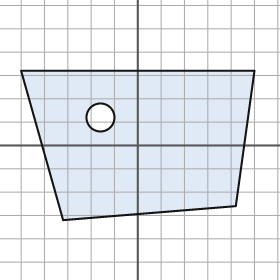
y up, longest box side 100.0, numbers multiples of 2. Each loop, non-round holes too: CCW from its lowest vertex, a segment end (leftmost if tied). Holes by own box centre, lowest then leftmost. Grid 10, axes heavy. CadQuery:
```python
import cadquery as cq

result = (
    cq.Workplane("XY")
    .moveTo(-32.0, -32.0)
    .lineTo(42.0, -26.0)
    .lineTo(50.0, 32.0)
    .lineTo(-50.0, 32.0)
    .close()
    .moveTo(-16.0, 12.0)
    .circle(6.0)
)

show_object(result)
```